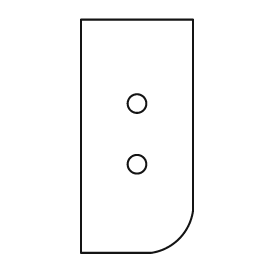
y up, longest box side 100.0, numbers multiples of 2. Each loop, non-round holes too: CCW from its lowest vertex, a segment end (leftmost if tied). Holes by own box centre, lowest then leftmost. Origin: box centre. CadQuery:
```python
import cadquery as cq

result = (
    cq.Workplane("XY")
    .moveTo(-24.0, -50.0)
    .lineTo(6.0, -50.0)
    .threePointArc((18.0, -44.0), (24.0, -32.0))
    .lineTo(24.0, 50.0)
    .lineTo(-24.0, 50.0)
    .close()
    .moveTo(0.0, -12.0)
    .circle(4.0)
    .moveTo(0.0, 14.0)
    .circle(4.0)
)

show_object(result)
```